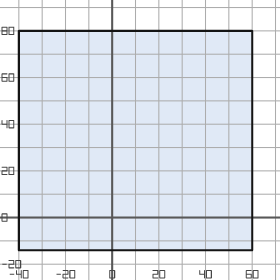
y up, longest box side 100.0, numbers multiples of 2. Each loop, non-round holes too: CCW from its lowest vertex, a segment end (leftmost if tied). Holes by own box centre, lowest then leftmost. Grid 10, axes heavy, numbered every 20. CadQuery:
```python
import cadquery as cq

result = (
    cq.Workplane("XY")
    .moveTo(-40.0, -14.0)
    .lineTo(60.0, -14.0)
    .lineTo(60.0, 80.0)
    .lineTo(-40.0, 80.0)
    .close()
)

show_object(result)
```